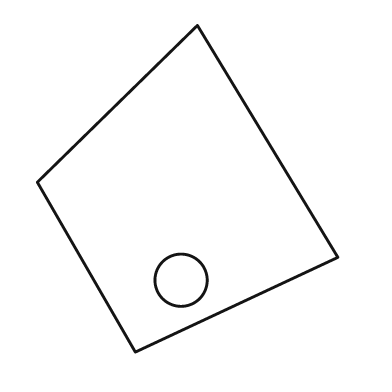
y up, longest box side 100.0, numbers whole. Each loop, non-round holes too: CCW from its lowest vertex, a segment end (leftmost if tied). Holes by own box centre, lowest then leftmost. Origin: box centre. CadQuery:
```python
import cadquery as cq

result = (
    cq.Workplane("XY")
    .moveTo(-16.0, -50.0)
    .lineTo(46.0, -21.0)
    .lineTo(3.0, 50.0)
    .lineTo(-46.0, 2.0)
    .close()
    .moveTo(-2.0, -28.0)
    .circle(8.0)
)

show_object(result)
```